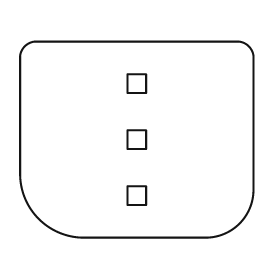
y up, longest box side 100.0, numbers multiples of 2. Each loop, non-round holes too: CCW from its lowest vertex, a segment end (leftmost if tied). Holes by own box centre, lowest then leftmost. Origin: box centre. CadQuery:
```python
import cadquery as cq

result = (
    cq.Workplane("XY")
    .moveTo(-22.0, -42.0)
    .lineTo(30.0, -42.0)
    .threePointArc((44.0, -36.0), (50.0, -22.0))
    .lineTo(50.0, 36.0)
    .threePointArc((48.0, 40.0), (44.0, 42.0))
    .lineTo(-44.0, 42.0)
    .threePointArc((-48.0, 40.0), (-50.0, 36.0))
    .lineTo(-50.0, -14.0)
    .threePointArc((-42.0, -34.0), (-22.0, -42.0))
    .close()
    .moveTo(-4.0, -28.0)
    .lineTo(4.0, -28.0)
    .lineTo(4.0, -20.0)
    .lineTo(-4.0, -20.0)
    .close()
    .moveTo(-4.0, -4.0)
    .lineTo(4.0, -4.0)
    .lineTo(4.0, 4.0)
    .lineTo(-4.0, 4.0)
    .close()
    .moveTo(-4.0, 20.0)
    .lineTo(4.0, 20.0)
    .lineTo(4.0, 28.0)
    .lineTo(-4.0, 28.0)
    .close()
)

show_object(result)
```